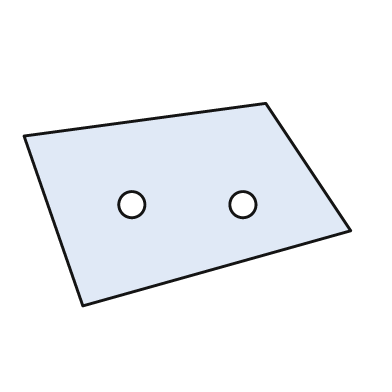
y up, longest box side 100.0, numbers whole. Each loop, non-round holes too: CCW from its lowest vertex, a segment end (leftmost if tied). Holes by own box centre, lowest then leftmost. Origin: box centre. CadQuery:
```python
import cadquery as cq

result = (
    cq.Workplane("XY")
    .moveTo(-32.0, -31.0)
    .lineTo(50.0, -8.0)
    .lineTo(24.0, 31.0)
    .lineTo(-50.0, 21.0)
    .close()
    .moveTo(-17.0, 0.0)
    .circle(4.0)
    .moveTo(17.0, 0.0)
    .circle(4.0)
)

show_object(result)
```